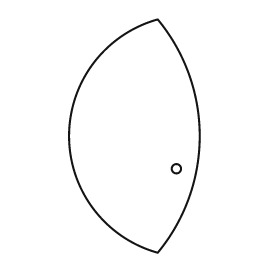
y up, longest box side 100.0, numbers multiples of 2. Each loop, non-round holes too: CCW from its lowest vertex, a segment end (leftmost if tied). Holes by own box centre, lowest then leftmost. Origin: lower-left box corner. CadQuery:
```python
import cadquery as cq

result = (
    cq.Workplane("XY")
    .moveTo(38.0, 0.0)
    .threePointArc((56.0, 50.0), (38.0, 100.0))
    .threePointArc((0.0, 50.0), (38.0, 0.0))
    .close()
    .moveTo(46.0, 36.0)
    .circle(2.0)
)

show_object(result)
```